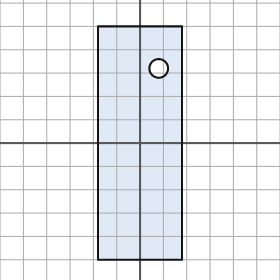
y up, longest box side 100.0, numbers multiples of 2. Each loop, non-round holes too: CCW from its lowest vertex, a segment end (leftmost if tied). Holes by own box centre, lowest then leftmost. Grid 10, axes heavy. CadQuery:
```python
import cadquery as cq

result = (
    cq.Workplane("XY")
    .moveTo(-18.0, -50.0)
    .lineTo(18.0, -50.0)
    .lineTo(18.0, 50.0)
    .lineTo(-18.0, 50.0)
    .close()
    .moveTo(8.0, 32.0)
    .circle(4.0)
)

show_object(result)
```